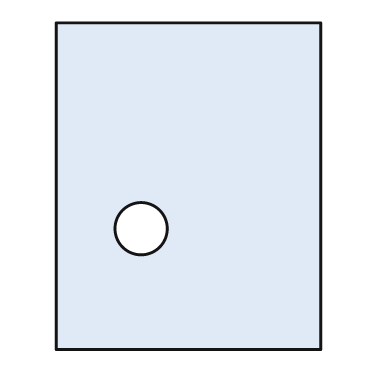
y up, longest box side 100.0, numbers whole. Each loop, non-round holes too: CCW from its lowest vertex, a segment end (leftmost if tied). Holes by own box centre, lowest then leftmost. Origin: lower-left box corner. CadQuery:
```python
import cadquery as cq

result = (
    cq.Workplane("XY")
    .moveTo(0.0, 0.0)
    .lineTo(81.0, 0.0)
    .lineTo(81.0, 100.0)
    .lineTo(0.0, 100.0)
    .close()
    .moveTo(26.0, 37.0)
    .circle(8.0)
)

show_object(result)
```